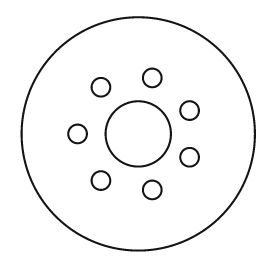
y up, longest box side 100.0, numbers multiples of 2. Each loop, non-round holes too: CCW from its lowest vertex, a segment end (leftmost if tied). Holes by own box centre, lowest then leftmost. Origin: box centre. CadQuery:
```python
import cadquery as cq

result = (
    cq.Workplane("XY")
    .moveTo(0.0, 0.0)
    .circle(50.0)
    .moveTo(6.0, -24.0)
    .circle(4.0)
    .moveTo(-16.0, -20.0)
    .circle(4.0)
    .moveTo(22.0, -10.0)
    .circle(4.0)
    .moveTo(-26.0, 0.0)
    .circle(4.0)
    .moveTo(0.0, 0.0)
    .circle(14.0)
    .moveTo(22.0, 10.0)
    .circle(4.0)
    .moveTo(-16.0, 20.0)
    .circle(4.0)
    .moveTo(6.0, 24.0)
    .circle(4.0)
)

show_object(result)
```